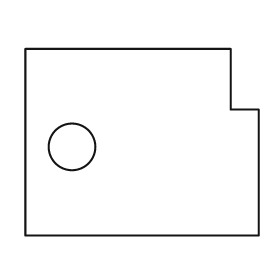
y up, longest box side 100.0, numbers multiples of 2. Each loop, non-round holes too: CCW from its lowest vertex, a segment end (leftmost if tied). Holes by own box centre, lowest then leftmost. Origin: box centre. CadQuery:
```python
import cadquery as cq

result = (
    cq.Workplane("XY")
    .moveTo(-50.0, -40.0)
    .lineTo(50.0, -40.0)
    .lineTo(50.0, 14.0)
    .lineTo(38.0, 14.0)
    .lineTo(38.0, 40.0)
    .lineTo(-50.0, 40.0)
    .close()
    .moveTo(-30.0, -2.0)
    .circle(10.0)
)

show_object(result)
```